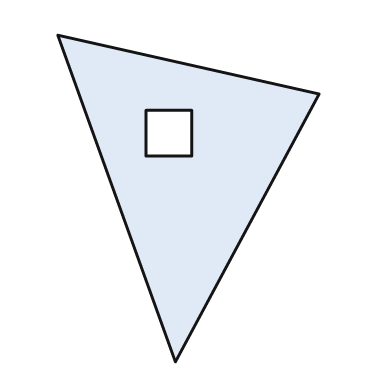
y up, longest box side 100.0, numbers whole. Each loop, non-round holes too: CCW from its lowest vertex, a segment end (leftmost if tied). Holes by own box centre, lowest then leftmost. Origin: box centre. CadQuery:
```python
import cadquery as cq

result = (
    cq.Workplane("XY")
    .moveTo(-4.0, -50.0)
    .lineTo(40.0, 32.0)
    .lineTo(-40.0, 50.0)
    .close()
    .moveTo(-13.0, 13.0)
    .lineTo(1.0, 13.0)
    .lineTo(1.0, 27.0)
    .lineTo(-13.0, 27.0)
    .close()
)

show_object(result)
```